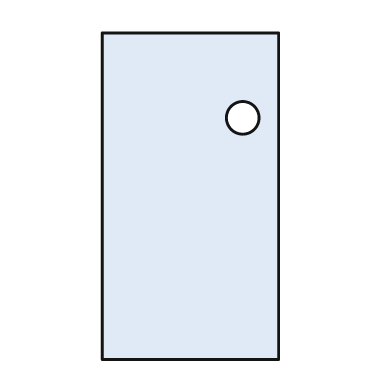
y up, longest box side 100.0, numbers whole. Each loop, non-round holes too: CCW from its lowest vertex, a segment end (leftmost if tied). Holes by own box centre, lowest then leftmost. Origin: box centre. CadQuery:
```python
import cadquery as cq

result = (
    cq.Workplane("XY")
    .moveTo(-27.0, -50.0)
    .lineTo(27.0, -50.0)
    .lineTo(27.0, 50.0)
    .lineTo(-27.0, 50.0)
    .close()
    .moveTo(16.0, 24.0)
    .circle(5.0)
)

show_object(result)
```